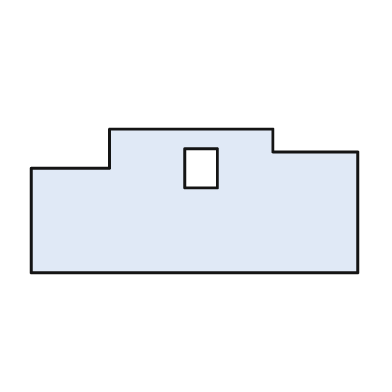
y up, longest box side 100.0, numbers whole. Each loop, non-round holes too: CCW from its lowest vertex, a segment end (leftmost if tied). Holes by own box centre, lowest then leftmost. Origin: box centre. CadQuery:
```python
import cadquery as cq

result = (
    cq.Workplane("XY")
    .moveTo(-50.0, -22.0)
    .lineTo(50.0, -22.0)
    .lineTo(50.0, 15.0)
    .lineTo(24.0, 15.0)
    .lineTo(24.0, 22.0)
    .lineTo(-26.0, 22.0)
    .lineTo(-26.0, 10.0)
    .lineTo(-50.0, 10.0)
    .close()
    .moveTo(-3.0, 4.0)
    .lineTo(7.0, 4.0)
    .lineTo(7.0, 16.0)
    .lineTo(-3.0, 16.0)
    .close()
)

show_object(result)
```